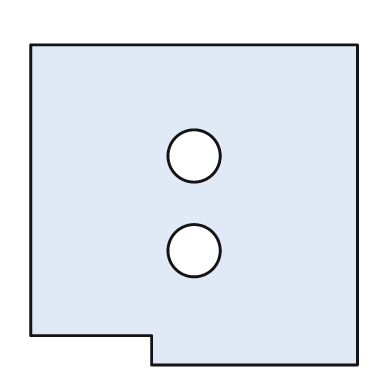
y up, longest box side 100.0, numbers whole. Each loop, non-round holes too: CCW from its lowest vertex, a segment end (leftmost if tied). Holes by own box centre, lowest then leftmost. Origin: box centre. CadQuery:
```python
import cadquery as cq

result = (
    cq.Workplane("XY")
    .moveTo(-13.0, -49.0)
    .lineTo(50.0, -49.0)
    .lineTo(50.0, 49.0)
    .lineTo(-50.0, 49.0)
    .lineTo(-50.0, -40.0)
    .lineTo(-13.0, -40.0)
    .close()
    .moveTo(0.0, -14.0)
    .circle(8.0)
    .moveTo(0.0, 15.0)
    .circle(8.0)
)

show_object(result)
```